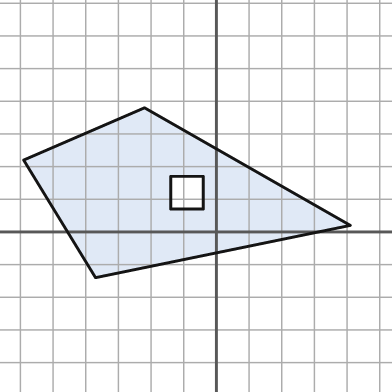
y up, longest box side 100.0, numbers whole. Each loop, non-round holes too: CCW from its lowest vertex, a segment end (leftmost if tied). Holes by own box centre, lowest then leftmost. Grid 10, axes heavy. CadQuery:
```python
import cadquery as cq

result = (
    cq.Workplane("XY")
    .moveTo(-37.0, -14.0)
    .lineTo(41.0, 2.0)
    .lineTo(-22.0, 38.0)
    .lineTo(-59.0, 22.0)
    .close()
    .moveTo(-14.0, 7.0)
    .lineTo(-4.0, 7.0)
    .lineTo(-4.0, 17.0)
    .lineTo(-14.0, 17.0)
    .close()
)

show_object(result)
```